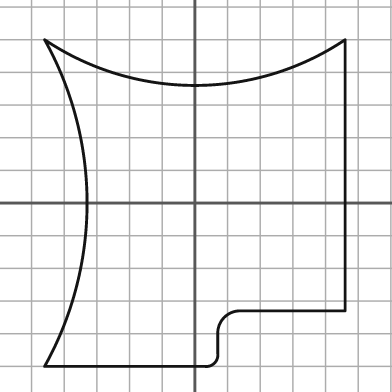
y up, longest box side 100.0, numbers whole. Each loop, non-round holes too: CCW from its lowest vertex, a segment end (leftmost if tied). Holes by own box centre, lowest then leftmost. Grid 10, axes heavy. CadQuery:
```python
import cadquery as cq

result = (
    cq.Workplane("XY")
    .moveTo(-46.0, -50.0)
    .lineTo(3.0, -50.0)
    .threePointArc((6.0, -49.0), (7.0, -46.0))
    .lineTo(7.0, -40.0)
    .threePointArc((9.0, -35.0), (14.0, -33.0))
    .lineTo(46.0, -33.0)
    .lineTo(46.0, 50.0)
    .threePointArc((0.0, 36.0), (-46.0, 50.0))
    .threePointArc((-33.0, 0.0), (-46.0, -50.0))
    .close()
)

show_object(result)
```